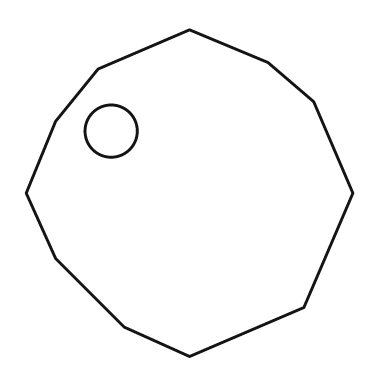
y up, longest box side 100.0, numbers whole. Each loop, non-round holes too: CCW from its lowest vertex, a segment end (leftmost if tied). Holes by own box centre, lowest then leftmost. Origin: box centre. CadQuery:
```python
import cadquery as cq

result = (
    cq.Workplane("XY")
    .moveTo(0.0, -50.0)
    .lineTo(35.0, -35.0)
    .lineTo(50.0, 0.0)
    .lineTo(38.0, 28.0)
    .lineTo(24.0, 40.0)
    .lineTo(0.0, 50.0)
    .lineTo(-28.0, 38.0)
    .lineTo(-41.0, 22.0)
    .lineTo(-50.0, 0.0)
    .lineTo(-41.0, -20.0)
    .lineTo(-20.0, -41.0)
    .close()
    .moveTo(-24.0, 19.0)
    .circle(8.0)
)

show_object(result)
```